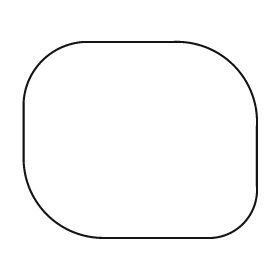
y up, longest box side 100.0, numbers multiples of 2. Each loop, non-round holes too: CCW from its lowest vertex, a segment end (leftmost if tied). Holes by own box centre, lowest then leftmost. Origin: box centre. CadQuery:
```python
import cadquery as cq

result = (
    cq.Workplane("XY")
    .moveTo(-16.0, -42.0)
    .lineTo(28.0, -42.0)
    .threePointArc((44.0, -36.0), (50.0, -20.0))
    .lineTo(50.0, 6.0)
    .threePointArc((40.0, 32.0), (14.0, 42.0))
    .lineTo(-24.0, 42.0)
    .threePointArc((-42.0, 34.0), (-50.0, 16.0))
    .lineTo(-50.0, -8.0)
    .threePointArc((-40.0, -32.0), (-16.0, -42.0))
    .close()
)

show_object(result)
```